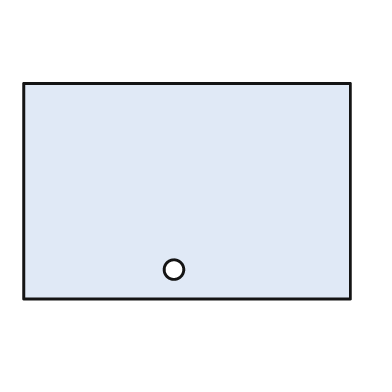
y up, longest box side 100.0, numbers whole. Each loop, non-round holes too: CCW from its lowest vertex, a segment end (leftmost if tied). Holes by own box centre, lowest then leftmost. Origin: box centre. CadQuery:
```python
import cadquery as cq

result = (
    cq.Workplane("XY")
    .moveTo(-50.0, -33.0)
    .lineTo(50.0, -33.0)
    .lineTo(50.0, 33.0)
    .lineTo(-50.0, 33.0)
    .close()
    .moveTo(-4.0, -24.0)
    .circle(3.0)
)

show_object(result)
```